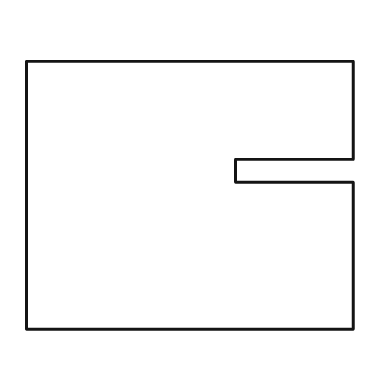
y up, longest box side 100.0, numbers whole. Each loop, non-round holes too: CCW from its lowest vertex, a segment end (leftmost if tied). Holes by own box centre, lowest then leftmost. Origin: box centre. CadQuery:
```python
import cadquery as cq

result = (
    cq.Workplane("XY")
    .moveTo(-50.0, -41.0)
    .lineTo(50.0, -41.0)
    .lineTo(50.0, 4.0)
    .lineTo(14.0, 4.0)
    .lineTo(14.0, 11.0)
    .lineTo(50.0, 11.0)
    .lineTo(50.0, 41.0)
    .lineTo(-50.0, 41.0)
    .close()
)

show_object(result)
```